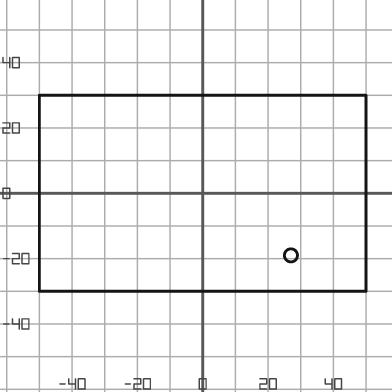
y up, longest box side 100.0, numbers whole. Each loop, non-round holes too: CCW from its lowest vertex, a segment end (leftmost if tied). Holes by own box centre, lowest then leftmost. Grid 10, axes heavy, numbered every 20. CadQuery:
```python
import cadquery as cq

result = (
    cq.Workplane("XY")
    .moveTo(-50.0, -30.0)
    .lineTo(50.0, -30.0)
    .lineTo(50.0, 30.0)
    .lineTo(-50.0, 30.0)
    .close()
    .moveTo(27.0, -19.0)
    .circle(2.0)
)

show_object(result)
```